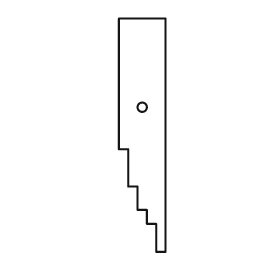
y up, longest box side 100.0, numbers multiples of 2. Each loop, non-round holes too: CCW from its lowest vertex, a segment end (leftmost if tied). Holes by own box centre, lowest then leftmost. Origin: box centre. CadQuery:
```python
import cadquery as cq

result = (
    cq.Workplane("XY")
    .moveTo(6.0, -50.0)
    .lineTo(10.0, -50.0)
    .lineTo(10.0, 50.0)
    .lineTo(-10.0, 50.0)
    .lineTo(-10.0, -6.0)
    .lineTo(-6.0, -6.0)
    .lineTo(-6.0, -22.0)
    .lineTo(-2.0, -22.0)
    .lineTo(-2.0, -32.0)
    .lineTo(2.0, -32.0)
    .lineTo(2.0, -38.0)
    .lineTo(6.0, -38.0)
    .close()
    .moveTo(0.0, 12.0)
    .circle(2.0)
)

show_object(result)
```